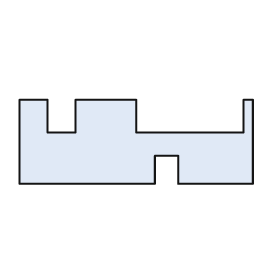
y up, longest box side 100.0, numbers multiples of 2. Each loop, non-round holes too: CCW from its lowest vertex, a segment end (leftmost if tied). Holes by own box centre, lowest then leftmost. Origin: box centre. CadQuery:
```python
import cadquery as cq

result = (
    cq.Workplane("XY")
    .moveTo(-50.0, -18.0)
    .lineTo(8.0, -18.0)
    .lineTo(8.0, -6.0)
    .lineTo(18.0, -6.0)
    .lineTo(18.0, -18.0)
    .lineTo(50.0, -18.0)
    .lineTo(50.0, 18.0)
    .lineTo(46.0, 18.0)
    .lineTo(46.0, 4.0)
    .lineTo(0.0, 4.0)
    .lineTo(0.0, 18.0)
    .lineTo(-26.0, 18.0)
    .lineTo(-26.0, 4.0)
    .lineTo(-38.0, 4.0)
    .lineTo(-38.0, 18.0)
    .lineTo(-50.0, 18.0)
    .close()
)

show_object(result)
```